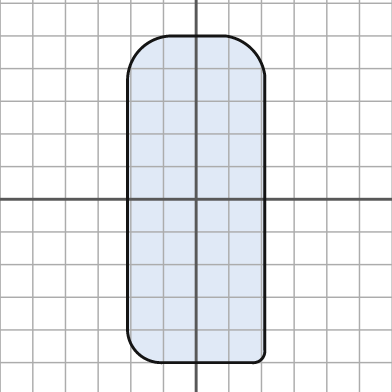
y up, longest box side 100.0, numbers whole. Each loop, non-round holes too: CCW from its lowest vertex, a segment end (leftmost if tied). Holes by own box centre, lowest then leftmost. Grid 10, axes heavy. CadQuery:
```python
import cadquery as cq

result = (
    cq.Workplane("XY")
    .moveTo(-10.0, -50.0)
    .lineTo(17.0, -50.0)
    .threePointArc((20.0, -49.0), (21.0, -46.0))
    .lineTo(21.0, 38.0)
    .threePointArc((17.0, 46.0), (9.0, 50.0))
    .lineTo(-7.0, 50.0)
    .threePointArc((-17.0, 46.0), (-21.0, 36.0))
    .lineTo(-21.0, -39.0)
    .threePointArc((-18.0, -47.0), (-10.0, -50.0))
    .close()
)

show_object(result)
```